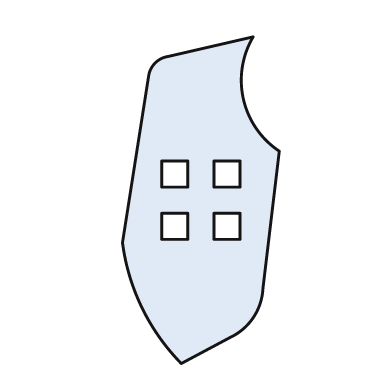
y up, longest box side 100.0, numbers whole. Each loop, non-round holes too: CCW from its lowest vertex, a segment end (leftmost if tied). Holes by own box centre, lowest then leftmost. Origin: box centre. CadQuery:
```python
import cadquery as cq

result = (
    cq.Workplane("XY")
    .moveTo(-6.0, -50.0)
    .lineTo(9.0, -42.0)
    .threePointArc((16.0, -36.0), (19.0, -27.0))
    .lineTo(24.0, 15.0)
    .threePointArc((13.0, 31.0), (16.0, 50.0))
    .lineTo(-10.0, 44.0)
    .threePointArc((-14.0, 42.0), (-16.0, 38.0))
    .lineTo(-24.0, -13.0)
    .threePointArc((-18.0, -33.0), (-6.0, -50.0))
    .close()
    .moveTo(-12.0, -12.0)
    .lineTo(-4.0, -12.0)
    .lineTo(-4.0, -4.0)
    .lineTo(-12.0, -4.0)
    .close()
    .moveTo(4.0, -12.0)
    .lineTo(12.0, -12.0)
    .lineTo(12.0, -4.0)
    .lineTo(4.0, -4.0)
    .close()
    .moveTo(-12.0, 4.0)
    .lineTo(-4.0, 4.0)
    .lineTo(-4.0, 12.0)
    .lineTo(-12.0, 12.0)
    .close()
    .moveTo(4.0, 4.0)
    .lineTo(12.0, 4.0)
    .lineTo(12.0, 12.0)
    .lineTo(4.0, 12.0)
    .close()
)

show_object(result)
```